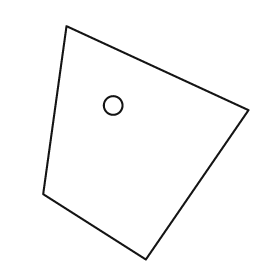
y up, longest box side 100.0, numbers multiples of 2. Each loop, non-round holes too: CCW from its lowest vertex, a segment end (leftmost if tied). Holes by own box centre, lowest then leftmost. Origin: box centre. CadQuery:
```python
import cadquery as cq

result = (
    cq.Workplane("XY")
    .moveTo(0.0, -50.0)
    .lineTo(44.0, 14.0)
    .lineTo(-34.0, 50.0)
    .lineTo(-44.0, -22.0)
    .close()
    .moveTo(-14.0, 16.0)
    .circle(4.0)
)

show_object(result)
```